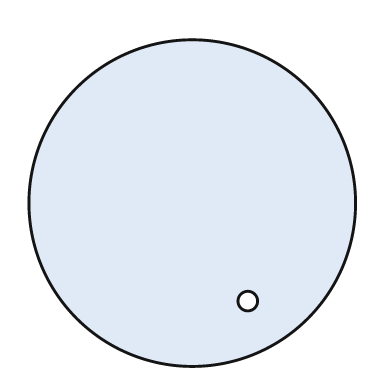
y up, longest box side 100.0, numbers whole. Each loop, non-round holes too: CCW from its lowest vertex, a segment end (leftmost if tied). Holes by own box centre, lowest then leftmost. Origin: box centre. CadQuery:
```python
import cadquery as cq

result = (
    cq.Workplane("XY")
    .moveTo(0.0, 0.0)
    .circle(50.0)
    .moveTo(17.0, -30.0)
    .circle(3.0)
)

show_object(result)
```